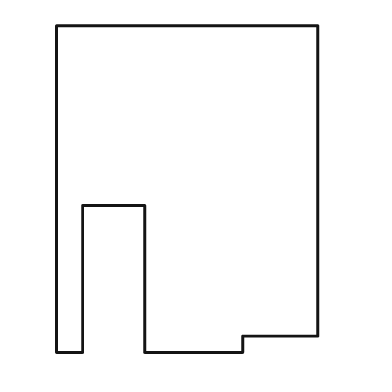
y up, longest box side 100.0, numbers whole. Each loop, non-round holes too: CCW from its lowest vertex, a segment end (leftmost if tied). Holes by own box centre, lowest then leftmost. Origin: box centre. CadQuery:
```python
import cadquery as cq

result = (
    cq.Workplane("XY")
    .moveTo(-40.0, -50.0)
    .lineTo(-32.0, -50.0)
    .lineTo(-32.0, -5.0)
    .lineTo(-13.0, -5.0)
    .lineTo(-13.0, -50.0)
    .lineTo(17.0, -50.0)
    .lineTo(17.0, -45.0)
    .lineTo(40.0, -45.0)
    .lineTo(40.0, 50.0)
    .lineTo(-40.0, 50.0)
    .close()
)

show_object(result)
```